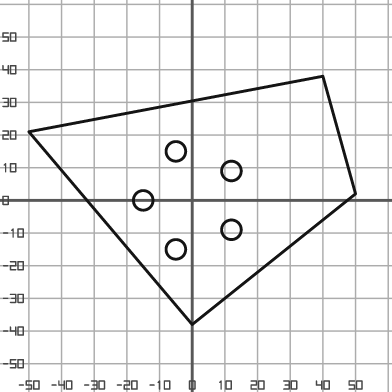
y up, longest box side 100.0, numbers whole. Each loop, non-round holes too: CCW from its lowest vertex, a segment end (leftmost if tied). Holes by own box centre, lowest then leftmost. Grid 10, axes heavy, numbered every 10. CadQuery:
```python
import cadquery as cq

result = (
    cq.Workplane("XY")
    .moveTo(0.0, -38.0)
    .lineTo(50.0, 2.0)
    .lineTo(40.0, 38.0)
    .lineTo(-50.0, 21.0)
    .close()
    .moveTo(-5.0, -15.0)
    .circle(3.0)
    .moveTo(12.0, -9.0)
    .circle(3.0)
    .moveTo(-15.0, 0.0)
    .circle(3.0)
    .moveTo(12.0, 9.0)
    .circle(3.0)
    .moveTo(-5.0, 15.0)
    .circle(3.0)
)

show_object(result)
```